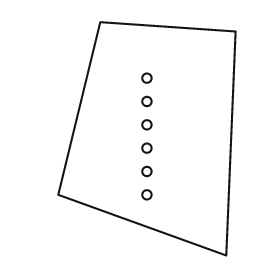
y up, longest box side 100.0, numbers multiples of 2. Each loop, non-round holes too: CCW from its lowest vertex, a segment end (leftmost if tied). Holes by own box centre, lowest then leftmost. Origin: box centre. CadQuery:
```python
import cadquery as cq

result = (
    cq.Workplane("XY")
    .moveTo(34.0, -50.0)
    .lineTo(38.0, 46.0)
    .lineTo(-20.0, 50.0)
    .lineTo(-38.0, -24.0)
    .close()
    .moveTo(0.0, -24.0)
    .circle(2.0)
    .moveTo(0.0, -14.0)
    .circle(2.0)
    .moveTo(0.0, -4.0)
    .circle(2.0)
    .moveTo(0.0, 6.0)
    .circle(2.0)
    .moveTo(0.0, 16.0)
    .circle(2.0)
    .moveTo(0.0, 26.0)
    .circle(2.0)
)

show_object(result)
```